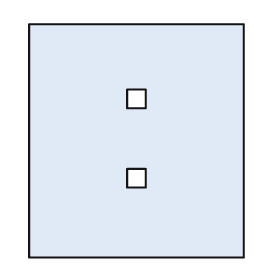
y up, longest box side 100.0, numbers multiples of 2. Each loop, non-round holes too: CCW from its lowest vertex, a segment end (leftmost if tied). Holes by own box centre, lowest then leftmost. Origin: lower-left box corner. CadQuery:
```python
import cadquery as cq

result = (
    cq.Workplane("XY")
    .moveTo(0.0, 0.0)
    .lineTo(92.0, 0.0)
    .lineTo(92.0, 100.0)
    .lineTo(0.0, 100.0)
    .close()
    .moveTo(42.0, 30.0)
    .lineTo(50.0, 30.0)
    .lineTo(50.0, 38.0)
    .lineTo(42.0, 38.0)
    .close()
    .moveTo(42.0, 64.0)
    .lineTo(50.0, 64.0)
    .lineTo(50.0, 72.0)
    .lineTo(42.0, 72.0)
    .close()
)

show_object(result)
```